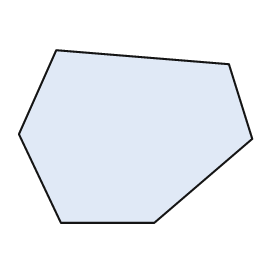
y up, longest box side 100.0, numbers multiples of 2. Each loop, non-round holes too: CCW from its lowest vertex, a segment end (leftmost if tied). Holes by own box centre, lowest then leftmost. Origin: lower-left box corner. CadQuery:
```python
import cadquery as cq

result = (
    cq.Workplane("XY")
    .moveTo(18.0, 0.0)
    .lineTo(58.0, 0.0)
    .lineTo(100.0, 36.0)
    .lineTo(90.0, 68.0)
    .lineTo(16.0, 74.0)
    .lineTo(0.0, 38.0)
    .close()
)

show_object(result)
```